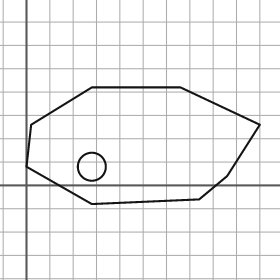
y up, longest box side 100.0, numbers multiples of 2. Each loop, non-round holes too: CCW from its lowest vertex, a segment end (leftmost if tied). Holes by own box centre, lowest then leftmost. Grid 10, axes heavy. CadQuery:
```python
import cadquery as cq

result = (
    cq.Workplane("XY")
    .moveTo(28.0, -8.0)
    .lineTo(74.0, -6.0)
    .lineTo(86.0, 4.0)
    .lineTo(100.0, 26.0)
    .lineTo(66.0, 42.0)
    .lineTo(28.0, 42.0)
    .lineTo(2.0, 26.0)
    .lineTo(0.0, 8.0)
    .close()
    .moveTo(28.0, 8.0)
    .circle(6.0)
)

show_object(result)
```